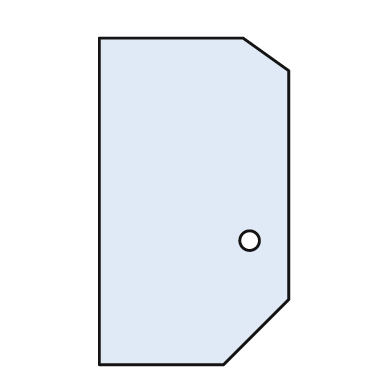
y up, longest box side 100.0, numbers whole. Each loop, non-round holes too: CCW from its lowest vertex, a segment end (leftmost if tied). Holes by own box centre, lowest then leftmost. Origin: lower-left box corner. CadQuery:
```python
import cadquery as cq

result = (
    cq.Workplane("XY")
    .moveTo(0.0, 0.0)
    .lineTo(38.0, 0.0)
    .lineTo(58.0, 20.0)
    .lineTo(58.0, 90.0)
    .lineTo(44.0, 100.0)
    .lineTo(0.0, 100.0)
    .close()
    .moveTo(46.0, 38.0)
    .circle(3.0)
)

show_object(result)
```